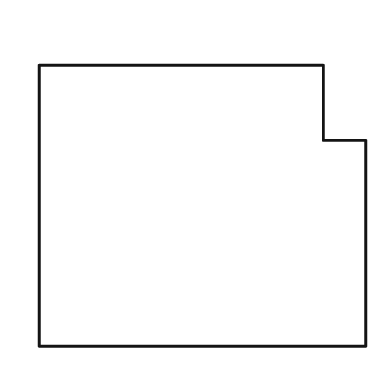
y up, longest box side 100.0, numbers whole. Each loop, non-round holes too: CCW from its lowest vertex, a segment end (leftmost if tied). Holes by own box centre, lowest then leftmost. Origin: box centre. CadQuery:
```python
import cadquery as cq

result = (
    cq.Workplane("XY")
    .moveTo(-50.0, -43.0)
    .lineTo(50.0, -43.0)
    .lineTo(50.0, 20.0)
    .lineTo(37.0, 20.0)
    .lineTo(37.0, 43.0)
    .lineTo(-50.0, 43.0)
    .close()
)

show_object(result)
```